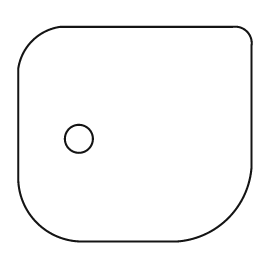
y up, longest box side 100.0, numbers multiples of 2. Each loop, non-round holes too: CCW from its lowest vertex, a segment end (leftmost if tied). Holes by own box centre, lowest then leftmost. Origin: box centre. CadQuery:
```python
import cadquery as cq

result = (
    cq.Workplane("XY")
    .moveTo(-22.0, -46.0)
    .lineTo(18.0, -46.0)
    .threePointArc((40.0, -36.0), (50.0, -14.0))
    .lineTo(50.0, 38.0)
    .threePointArc((48.0, 44.0), (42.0, 46.0))
    .lineTo(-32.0, 46.0)
    .threePointArc((-44.0, 40.0), (-50.0, 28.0))
    .lineTo(-50.0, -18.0)
    .threePointArc((-42.0, -38.0), (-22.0, -46.0))
    .close()
    .moveTo(-24.0, -2.0)
    .circle(6.0)
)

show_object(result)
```